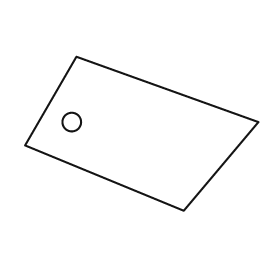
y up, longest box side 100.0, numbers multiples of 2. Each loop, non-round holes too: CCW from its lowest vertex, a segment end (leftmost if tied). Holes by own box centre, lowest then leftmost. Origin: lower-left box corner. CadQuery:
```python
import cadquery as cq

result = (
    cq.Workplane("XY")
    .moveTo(68.0, 0.0)
    .lineTo(100.0, 38.0)
    .lineTo(22.0, 66.0)
    .lineTo(0.0, 28.0)
    .close()
    .moveTo(20.0, 38.0)
    .circle(4.0)
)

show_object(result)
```